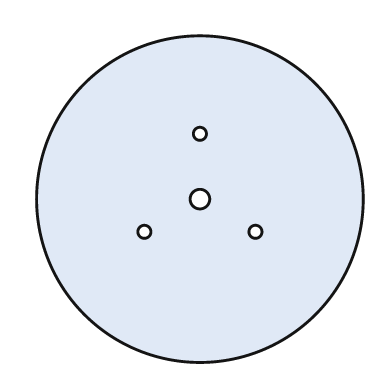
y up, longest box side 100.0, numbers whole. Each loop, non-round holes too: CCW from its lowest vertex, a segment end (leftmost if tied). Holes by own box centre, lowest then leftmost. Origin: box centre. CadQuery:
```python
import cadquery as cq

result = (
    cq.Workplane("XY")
    .moveTo(0.0, 0.0)
    .circle(50.0)
    .moveTo(-17.0, -10.0)
    .circle(2.0)
    .moveTo(17.0, -10.0)
    .circle(2.0)
    .moveTo(0.0, 0.0)
    .circle(3.0)
    .moveTo(0.0, 20.0)
    .circle(2.0)
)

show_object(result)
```